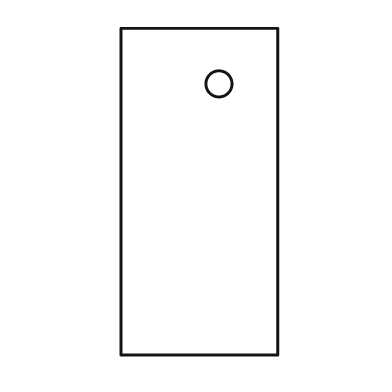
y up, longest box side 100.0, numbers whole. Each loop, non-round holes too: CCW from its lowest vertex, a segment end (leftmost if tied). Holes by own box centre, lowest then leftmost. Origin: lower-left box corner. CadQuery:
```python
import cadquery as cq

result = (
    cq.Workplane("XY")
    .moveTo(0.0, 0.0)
    .lineTo(48.0, 0.0)
    .lineTo(48.0, 100.0)
    .lineTo(0.0, 100.0)
    .close()
    .moveTo(30.0, 83.0)
    .circle(4.0)
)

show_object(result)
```